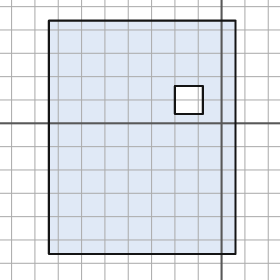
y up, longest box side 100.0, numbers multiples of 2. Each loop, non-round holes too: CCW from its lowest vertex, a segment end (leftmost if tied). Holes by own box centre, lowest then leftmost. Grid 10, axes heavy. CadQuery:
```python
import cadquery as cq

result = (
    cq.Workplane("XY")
    .moveTo(-74.0, -56.0)
    .lineTo(6.0, -56.0)
    .lineTo(6.0, 44.0)
    .lineTo(-74.0, 44.0)
    .close()
    .moveTo(-20.0, 4.0)
    .lineTo(-8.0, 4.0)
    .lineTo(-8.0, 16.0)
    .lineTo(-20.0, 16.0)
    .close()
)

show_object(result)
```